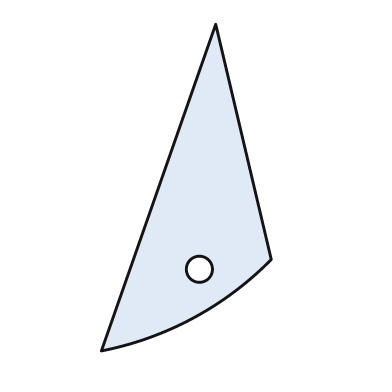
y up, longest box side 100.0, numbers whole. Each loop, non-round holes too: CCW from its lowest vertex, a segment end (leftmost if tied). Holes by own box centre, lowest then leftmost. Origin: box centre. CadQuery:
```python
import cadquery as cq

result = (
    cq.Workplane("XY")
    .moveTo(-26.0, -50.0)
    .threePointArc((2.0, -40.0), (26.0, -22.0))
    .lineTo(9.0, 50.0)
    .close()
    .moveTo(4.0, -25.0)
    .circle(4.0)
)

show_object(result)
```